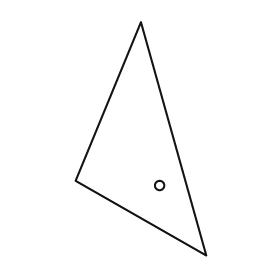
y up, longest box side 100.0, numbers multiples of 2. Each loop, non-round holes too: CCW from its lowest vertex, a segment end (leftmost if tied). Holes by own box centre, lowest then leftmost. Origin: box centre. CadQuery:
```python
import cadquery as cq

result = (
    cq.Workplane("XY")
    .moveTo(28.0, -50.0)
    .lineTo(0.0, 50.0)
    .lineTo(-28.0, -18.0)
    .close()
    .moveTo(8.0, -20.0)
    .circle(2.0)
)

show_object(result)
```